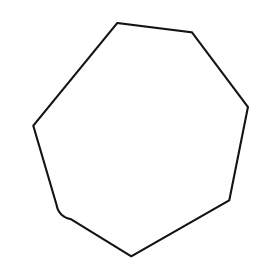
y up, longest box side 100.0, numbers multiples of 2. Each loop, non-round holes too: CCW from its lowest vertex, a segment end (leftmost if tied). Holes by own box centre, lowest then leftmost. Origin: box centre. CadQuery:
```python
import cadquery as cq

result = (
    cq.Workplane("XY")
    .moveTo(-4.0, -50.0)
    .lineTo(38.0, -26.0)
    .lineTo(46.0, 14.0)
    .lineTo(22.0, 46.0)
    .lineTo(-10.0, 50.0)
    .lineTo(-46.0, 6.0)
    .lineTo(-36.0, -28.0)
    .threePointArc((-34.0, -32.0), (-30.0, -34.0))
    .close()
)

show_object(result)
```